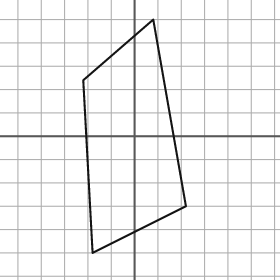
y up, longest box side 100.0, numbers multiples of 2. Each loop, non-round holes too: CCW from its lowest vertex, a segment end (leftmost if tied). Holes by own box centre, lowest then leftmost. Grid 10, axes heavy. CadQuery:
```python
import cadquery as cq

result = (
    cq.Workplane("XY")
    .moveTo(-18.0, -50.0)
    .lineTo(22.0, -30.0)
    .lineTo(8.0, 50.0)
    .lineTo(-22.0, 24.0)
    .close()
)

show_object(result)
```